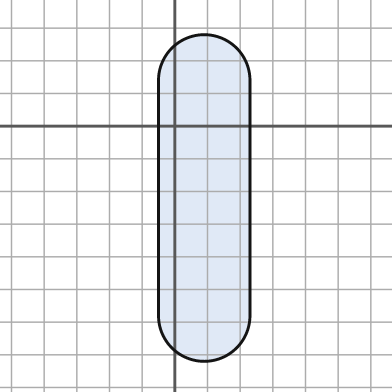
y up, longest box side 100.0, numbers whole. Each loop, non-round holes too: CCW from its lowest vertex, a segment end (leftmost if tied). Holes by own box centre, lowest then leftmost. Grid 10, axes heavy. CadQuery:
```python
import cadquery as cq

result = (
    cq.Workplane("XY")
    .moveTo(-5.0, -58.0)
    .threePointArc((9.0, -72.0), (23.0, -58.0))
    .lineTo(23.0, 14.0)
    .threePointArc((9.0, 28.0), (-5.0, 14.0))
    .close()
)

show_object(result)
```